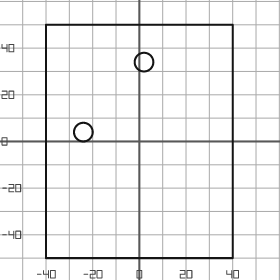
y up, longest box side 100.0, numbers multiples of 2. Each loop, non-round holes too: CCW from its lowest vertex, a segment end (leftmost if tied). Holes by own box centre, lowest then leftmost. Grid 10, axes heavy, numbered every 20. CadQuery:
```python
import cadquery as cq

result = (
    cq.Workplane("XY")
    .moveTo(-40.0, -50.0)
    .lineTo(40.0, -50.0)
    .lineTo(40.0, 50.0)
    .lineTo(-40.0, 50.0)
    .close()
    .moveTo(-24.0, 4.0)
    .circle(4.0)
    .moveTo(2.0, 34.0)
    .circle(4.0)
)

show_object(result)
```